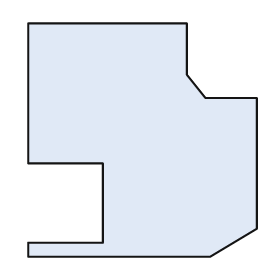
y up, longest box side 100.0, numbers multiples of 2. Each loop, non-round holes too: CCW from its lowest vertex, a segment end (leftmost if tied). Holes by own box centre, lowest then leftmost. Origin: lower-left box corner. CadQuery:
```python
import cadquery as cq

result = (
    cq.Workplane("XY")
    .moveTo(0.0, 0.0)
    .lineTo(78.0, 0.0)
    .lineTo(98.0, 12.0)
    .lineTo(98.0, 68.0)
    .lineTo(76.0, 68.0)
    .lineTo(68.0, 78.0)
    .lineTo(68.0, 100.0)
    .lineTo(0.0, 100.0)
    .lineTo(0.0, 40.0)
    .lineTo(32.0, 40.0)
    .lineTo(32.0, 6.0)
    .lineTo(0.0, 6.0)
    .close()
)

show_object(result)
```